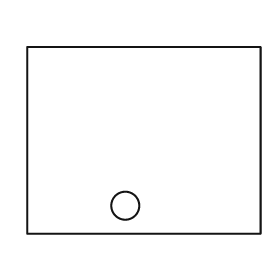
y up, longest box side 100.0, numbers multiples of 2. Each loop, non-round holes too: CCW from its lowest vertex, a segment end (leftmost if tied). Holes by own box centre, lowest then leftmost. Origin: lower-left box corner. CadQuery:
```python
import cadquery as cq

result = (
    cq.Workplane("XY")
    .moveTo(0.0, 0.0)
    .lineTo(100.0, 0.0)
    .lineTo(100.0, 80.0)
    .lineTo(0.0, 80.0)
    .close()
    .moveTo(42.0, 12.0)
    .circle(6.0)
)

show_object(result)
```